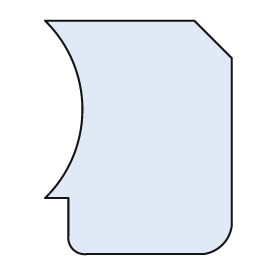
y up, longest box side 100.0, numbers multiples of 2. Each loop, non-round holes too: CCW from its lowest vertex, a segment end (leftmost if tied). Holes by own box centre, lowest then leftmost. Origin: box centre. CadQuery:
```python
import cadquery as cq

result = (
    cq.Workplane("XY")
    .moveTo(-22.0, -50.0)
    .lineTo(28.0, -50.0)
    .threePointArc((36.0, -46.0), (40.0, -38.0))
    .lineTo(40.0, 34.0)
    .lineTo(24.0, 50.0)
    .lineTo(-40.0, 50.0)
    .threePointArc((-24.0, 12.0), (-40.0, -26.0))
    .lineTo(-30.0, -26.0)
    .lineTo(-30.0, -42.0)
    .threePointArc((-28.0, -48.0), (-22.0, -50.0))
    .close()
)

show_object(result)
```